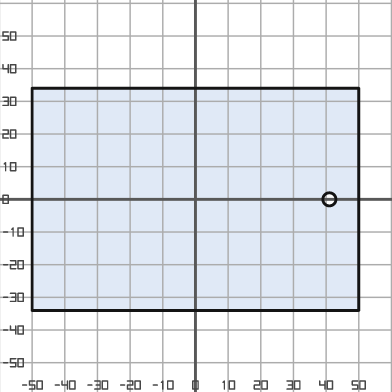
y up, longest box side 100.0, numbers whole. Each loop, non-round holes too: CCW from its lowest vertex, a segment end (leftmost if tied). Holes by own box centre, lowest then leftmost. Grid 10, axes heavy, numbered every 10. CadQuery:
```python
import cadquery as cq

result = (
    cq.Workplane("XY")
    .moveTo(-50.0, -34.0)
    .lineTo(50.0, -34.0)
    .lineTo(50.0, 34.0)
    .lineTo(-50.0, 34.0)
    .close()
    .moveTo(41.0, 0.0)
    .circle(2.0)
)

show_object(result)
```